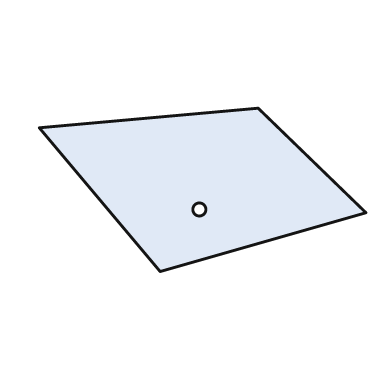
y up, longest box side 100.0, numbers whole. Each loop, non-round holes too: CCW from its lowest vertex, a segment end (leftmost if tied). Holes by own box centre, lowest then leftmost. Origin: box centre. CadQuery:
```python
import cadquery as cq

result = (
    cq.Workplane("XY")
    .moveTo(-13.0, -25.0)
    .lineTo(50.0, -7.0)
    .lineTo(17.0, 25.0)
    .lineTo(-50.0, 19.0)
    .close()
    .moveTo(-1.0, -6.0)
    .circle(2.0)
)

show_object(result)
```